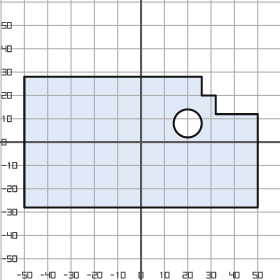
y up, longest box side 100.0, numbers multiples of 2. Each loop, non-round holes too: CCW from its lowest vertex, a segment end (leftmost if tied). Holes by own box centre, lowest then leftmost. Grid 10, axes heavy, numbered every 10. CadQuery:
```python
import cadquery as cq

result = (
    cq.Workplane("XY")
    .moveTo(-50.0, -28.0)
    .lineTo(50.0, -28.0)
    .lineTo(50.0, 12.0)
    .lineTo(32.0, 12.0)
    .lineTo(32.0, 20.0)
    .lineTo(26.0, 20.0)
    .lineTo(26.0, 28.0)
    .lineTo(-50.0, 28.0)
    .close()
    .moveTo(20.0, 8.0)
    .circle(6.0)
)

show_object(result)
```